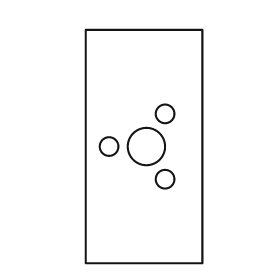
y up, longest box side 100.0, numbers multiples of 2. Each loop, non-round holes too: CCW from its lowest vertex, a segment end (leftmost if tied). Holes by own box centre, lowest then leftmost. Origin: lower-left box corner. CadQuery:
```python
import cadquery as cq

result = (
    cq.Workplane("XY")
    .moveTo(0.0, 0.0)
    .lineTo(50.0, 0.0)
    .lineTo(50.0, 100.0)
    .lineTo(0.0, 100.0)
    .close()
    .moveTo(34.0, 36.0)
    .circle(4.0)
    .moveTo(10.0, 50.0)
    .circle(4.0)
    .moveTo(26.0, 50.0)
    .circle(8.0)
    .moveTo(34.0, 64.0)
    .circle(4.0)
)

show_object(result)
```